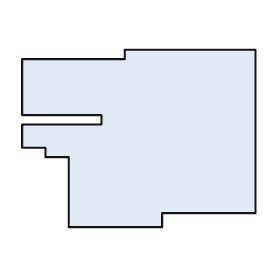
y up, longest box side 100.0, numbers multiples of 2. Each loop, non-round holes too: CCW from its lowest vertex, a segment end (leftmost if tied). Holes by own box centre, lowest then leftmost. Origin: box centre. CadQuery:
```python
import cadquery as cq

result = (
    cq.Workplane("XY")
    .moveTo(-30.0, -38.0)
    .lineTo(10.0, -38.0)
    .lineTo(10.0, -32.0)
    .lineTo(50.0, -32.0)
    .lineTo(50.0, 38.0)
    .lineTo(-6.0, 38.0)
    .lineTo(-6.0, 34.0)
    .lineTo(-50.0, 34.0)
    .lineTo(-50.0, 10.0)
    .lineTo(-16.0, 10.0)
    .lineTo(-16.0, 6.0)
    .lineTo(-50.0, 6.0)
    .lineTo(-50.0, -4.0)
    .lineTo(-40.0, -4.0)
    .lineTo(-40.0, -8.0)
    .lineTo(-30.0, -8.0)
    .close()
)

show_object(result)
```